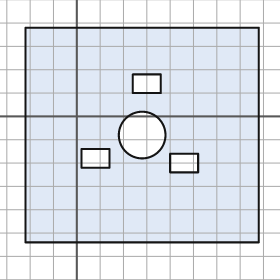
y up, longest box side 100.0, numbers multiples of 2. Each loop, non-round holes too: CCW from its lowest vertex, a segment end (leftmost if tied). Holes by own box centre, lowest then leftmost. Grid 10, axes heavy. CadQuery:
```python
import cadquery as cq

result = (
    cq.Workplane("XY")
    .moveTo(-22.0, -54.0)
    .lineTo(78.0, -54.0)
    .lineTo(78.0, 38.0)
    .lineTo(-22.0, 38.0)
    .close()
    .moveTo(40.0, -24.0)
    .lineTo(52.0, -24.0)
    .lineTo(52.0, -16.0)
    .lineTo(40.0, -16.0)
    .close()
    .moveTo(2.0, -22.0)
    .lineTo(14.0, -22.0)
    .lineTo(14.0, -14.0)
    .lineTo(2.0, -14.0)
    .close()
    .moveTo(28.0, -8.0)
    .circle(10.0)
    .moveTo(24.0, 10.0)
    .lineTo(36.0, 10.0)
    .lineTo(36.0, 18.0)
    .lineTo(24.0, 18.0)
    .close()
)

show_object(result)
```